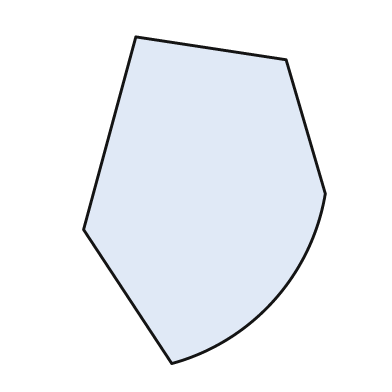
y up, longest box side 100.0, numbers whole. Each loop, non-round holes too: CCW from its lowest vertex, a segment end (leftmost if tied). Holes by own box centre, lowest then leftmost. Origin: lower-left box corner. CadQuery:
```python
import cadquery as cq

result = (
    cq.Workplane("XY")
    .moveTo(27.0, 0.0)
    .threePointArc((58.0, 19.0), (74.0, 52.0))
    .lineTo(62.0, 93.0)
    .lineTo(16.0, 100.0)
    .lineTo(0.0, 41.0)
    .close()
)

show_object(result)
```